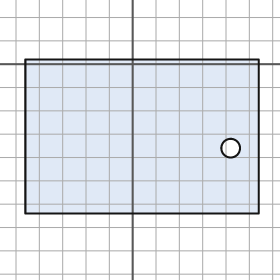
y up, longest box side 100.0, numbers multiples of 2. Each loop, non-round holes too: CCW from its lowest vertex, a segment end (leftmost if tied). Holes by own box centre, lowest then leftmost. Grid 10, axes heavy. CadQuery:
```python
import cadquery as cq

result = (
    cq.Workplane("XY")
    .moveTo(-46.0, -64.0)
    .lineTo(54.0, -64.0)
    .lineTo(54.0, 2.0)
    .lineTo(-46.0, 2.0)
    .close()
    .moveTo(42.0, -36.0)
    .circle(4.0)
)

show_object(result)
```